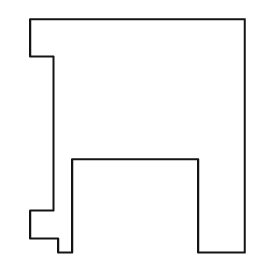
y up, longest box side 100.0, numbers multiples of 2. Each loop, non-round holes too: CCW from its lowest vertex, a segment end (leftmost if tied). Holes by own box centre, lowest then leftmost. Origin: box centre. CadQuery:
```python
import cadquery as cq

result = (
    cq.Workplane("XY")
    .moveTo(-34.0, -50.0)
    .lineTo(-28.0, -50.0)
    .lineTo(-28.0, -10.0)
    .lineTo(26.0, -10.0)
    .lineTo(26.0, -50.0)
    .lineTo(46.0, -50.0)
    .lineTo(46.0, 50.0)
    .lineTo(-46.0, 50.0)
    .lineTo(-46.0, 34.0)
    .lineTo(-36.0, 34.0)
    .lineTo(-36.0, -32.0)
    .lineTo(-46.0, -32.0)
    .lineTo(-46.0, -44.0)
    .lineTo(-34.0, -44.0)
    .close()
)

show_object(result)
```